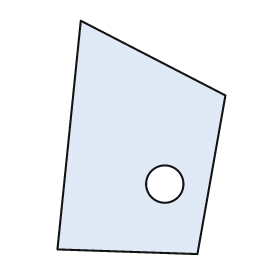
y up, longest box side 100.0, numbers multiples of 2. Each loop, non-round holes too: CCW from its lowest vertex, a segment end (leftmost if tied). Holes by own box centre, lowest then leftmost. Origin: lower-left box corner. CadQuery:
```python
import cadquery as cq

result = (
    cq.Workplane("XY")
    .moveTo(60.0, 0.0)
    .lineTo(72.0, 68.0)
    .lineTo(10.0, 100.0)
    .lineTo(0.0, 2.0)
    .close()
    .moveTo(46.0, 30.0)
    .circle(8.0)
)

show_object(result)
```